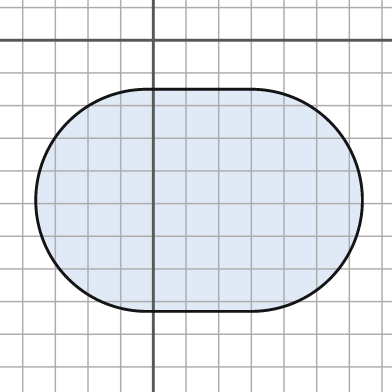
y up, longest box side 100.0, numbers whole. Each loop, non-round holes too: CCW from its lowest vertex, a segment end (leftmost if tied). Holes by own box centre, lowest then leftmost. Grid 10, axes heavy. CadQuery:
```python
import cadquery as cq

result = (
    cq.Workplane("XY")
    .moveTo(-2.0, -83.0)
    .lineTo(30.0, -83.0)
    .threePointArc((64.0, -49.0), (30.0, -15.0))
    .lineTo(-2.0, -15.0)
    .threePointArc((-36.0, -49.0), (-2.0, -83.0))
    .close()
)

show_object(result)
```